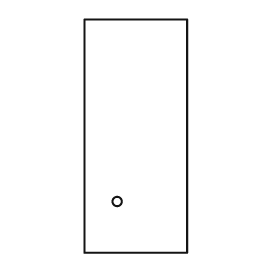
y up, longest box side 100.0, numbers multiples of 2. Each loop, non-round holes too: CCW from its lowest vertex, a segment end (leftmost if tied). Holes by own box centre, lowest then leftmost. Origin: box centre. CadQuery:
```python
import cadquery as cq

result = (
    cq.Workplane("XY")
    .moveTo(-22.0, -50.0)
    .lineTo(22.0, -50.0)
    .lineTo(22.0, 50.0)
    .lineTo(-22.0, 50.0)
    .close()
    .moveTo(-8.0, -28.0)
    .circle(2.0)
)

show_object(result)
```